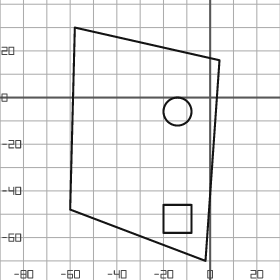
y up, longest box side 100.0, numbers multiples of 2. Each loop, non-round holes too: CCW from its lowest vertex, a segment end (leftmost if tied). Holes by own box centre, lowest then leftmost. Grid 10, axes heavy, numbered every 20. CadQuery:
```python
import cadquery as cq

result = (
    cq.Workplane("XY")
    .moveTo(-2.0, -70.0)
    .lineTo(4.0, 16.0)
    .lineTo(-58.0, 30.0)
    .lineTo(-60.0, -48.0)
    .close()
    .moveTo(-20.0, -58.0)
    .lineTo(-8.0, -58.0)
    .lineTo(-8.0, -46.0)
    .lineTo(-20.0, -46.0)
    .close()
    .moveTo(-14.0, -6.0)
    .circle(6.0)
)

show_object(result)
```